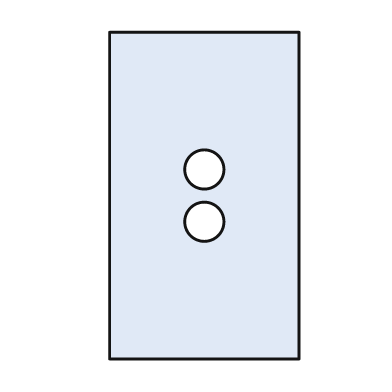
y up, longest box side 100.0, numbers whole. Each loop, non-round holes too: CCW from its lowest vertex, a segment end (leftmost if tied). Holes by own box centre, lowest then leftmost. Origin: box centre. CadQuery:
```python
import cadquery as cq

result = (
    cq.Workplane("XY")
    .moveTo(-29.0, -50.0)
    .lineTo(29.0, -50.0)
    .lineTo(29.0, 50.0)
    .lineTo(-29.0, 50.0)
    .close()
    .moveTo(0.0, -8.0)
    .circle(6.0)
    .moveTo(0.0, 8.0)
    .circle(6.0)
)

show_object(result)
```